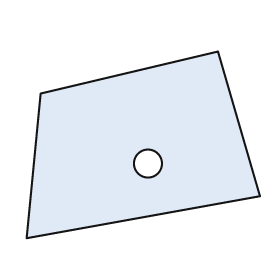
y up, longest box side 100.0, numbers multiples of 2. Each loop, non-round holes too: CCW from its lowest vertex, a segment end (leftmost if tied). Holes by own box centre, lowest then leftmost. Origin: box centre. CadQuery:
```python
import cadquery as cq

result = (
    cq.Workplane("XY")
    .moveTo(-50.0, -40.0)
    .lineTo(50.0, -22.0)
    .lineTo(32.0, 40.0)
    .lineTo(-44.0, 22.0)
    .close()
    .moveTo(2.0, -8.0)
    .circle(6.0)
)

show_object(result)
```